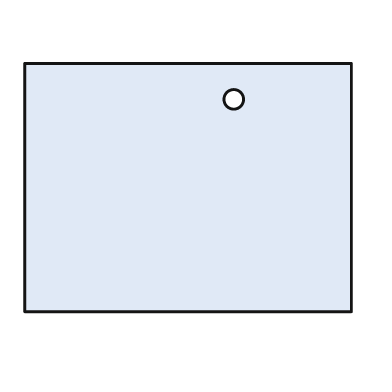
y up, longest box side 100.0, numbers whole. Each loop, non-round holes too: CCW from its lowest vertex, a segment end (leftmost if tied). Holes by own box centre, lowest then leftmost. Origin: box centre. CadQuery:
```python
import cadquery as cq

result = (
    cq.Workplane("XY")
    .moveTo(-50.0, -38.0)
    .lineTo(50.0, -38.0)
    .lineTo(50.0, 38.0)
    .lineTo(-50.0, 38.0)
    .close()
    .moveTo(14.0, 27.0)
    .circle(3.0)
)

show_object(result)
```